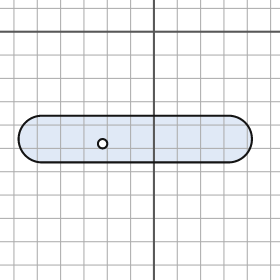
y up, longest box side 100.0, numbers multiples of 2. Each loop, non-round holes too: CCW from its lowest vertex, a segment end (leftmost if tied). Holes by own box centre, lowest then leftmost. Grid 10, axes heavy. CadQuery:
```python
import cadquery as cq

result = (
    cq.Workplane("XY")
    .moveTo(-48.0, -56.0)
    .lineTo(32.0, -56.0)
    .threePointArc((42.0, -46.0), (32.0, -36.0))
    .lineTo(-48.0, -36.0)
    .threePointArc((-58.0, -46.0), (-48.0, -56.0))
    .close()
    .moveTo(-22.0, -48.0)
    .circle(2.0)
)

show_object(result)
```